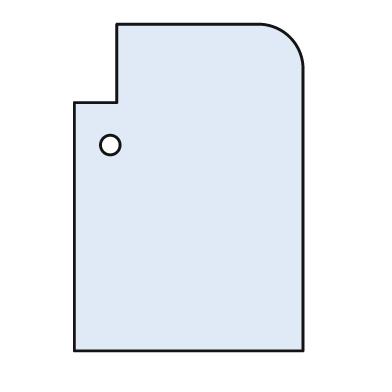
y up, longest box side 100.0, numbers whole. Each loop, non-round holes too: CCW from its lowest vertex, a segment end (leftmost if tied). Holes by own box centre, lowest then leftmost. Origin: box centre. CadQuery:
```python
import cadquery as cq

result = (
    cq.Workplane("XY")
    .moveTo(-35.0, -50.0)
    .lineTo(35.0, -50.0)
    .lineTo(35.0, 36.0)
    .threePointArc((31.0, 46.0), (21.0, 50.0))
    .lineTo(-22.0, 50.0)
    .lineTo(-22.0, 26.0)
    .lineTo(-35.0, 26.0)
    .close()
    .moveTo(-24.0, 13.0)
    .circle(3.0)
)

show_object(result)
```